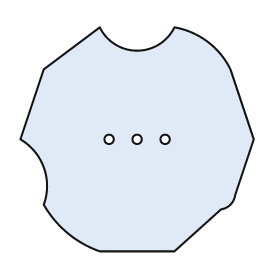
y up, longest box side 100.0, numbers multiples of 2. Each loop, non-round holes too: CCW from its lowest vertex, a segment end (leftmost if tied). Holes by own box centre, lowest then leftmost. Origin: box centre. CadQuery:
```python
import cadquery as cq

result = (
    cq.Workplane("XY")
    .moveTo(-16.0, -48.0)
    .lineTo(16.0, -48.0)
    .lineTo(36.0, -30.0)
    .threePointArc((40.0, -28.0), (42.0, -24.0))
    .lineTo(50.0, 0.0)
    .lineTo(40.0, 30.0)
    .threePointArc((30.0, 42.0), (16.0, 48.0))
    .threePointArc((0.0, 38.0), (-16.0, 48.0))
    .lineTo(-40.0, 30.0)
    .lineTo(-50.0, 0.0)
    .threePointArc((-40.0, -12.0), (-40.0, -28.0))
    .threePointArc((-30.0, -40.0), (-16.0, -48.0))
    .close()
    .moveTo(-12.0, 0.0)
    .circle(2.0)
    .moveTo(0.0, 0.0)
    .circle(2.0)
    .moveTo(12.0, 0.0)
    .circle(2.0)
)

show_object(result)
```